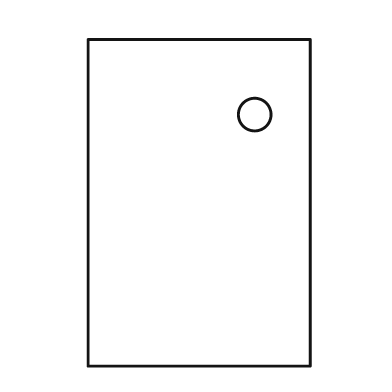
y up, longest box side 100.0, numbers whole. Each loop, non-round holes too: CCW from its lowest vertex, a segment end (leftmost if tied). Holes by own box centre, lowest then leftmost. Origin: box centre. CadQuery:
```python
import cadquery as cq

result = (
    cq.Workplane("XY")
    .moveTo(-34.0, -50.0)
    .lineTo(34.0, -50.0)
    .lineTo(34.0, 50.0)
    .lineTo(-34.0, 50.0)
    .close()
    .moveTo(17.0, 27.0)
    .circle(5.0)
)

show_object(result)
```